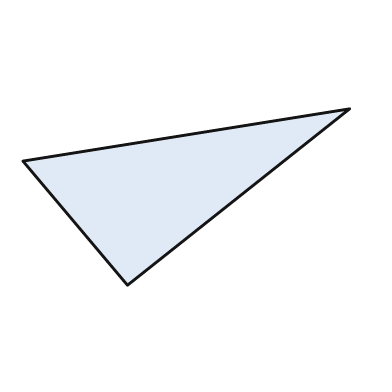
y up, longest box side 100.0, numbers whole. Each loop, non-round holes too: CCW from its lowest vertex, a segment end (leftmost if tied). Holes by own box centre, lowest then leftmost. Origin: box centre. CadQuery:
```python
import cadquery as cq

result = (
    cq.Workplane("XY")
    .moveTo(-18.0, -27.0)
    .lineTo(50.0, 27.0)
    .lineTo(-50.0, 11.0)
    .close()
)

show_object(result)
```